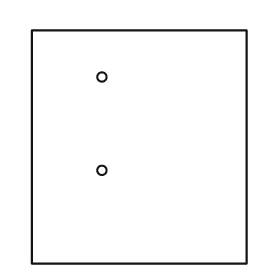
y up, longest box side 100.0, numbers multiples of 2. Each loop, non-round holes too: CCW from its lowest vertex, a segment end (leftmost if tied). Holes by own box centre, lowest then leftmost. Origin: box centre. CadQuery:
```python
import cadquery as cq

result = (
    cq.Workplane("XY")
    .moveTo(-46.0, -50.0)
    .lineTo(46.0, -50.0)
    .lineTo(46.0, 50.0)
    .lineTo(-46.0, 50.0)
    .close()
    .moveTo(-16.0, -10.0)
    .circle(2.0)
    .moveTo(-16.0, 30.0)
    .circle(2.0)
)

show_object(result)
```